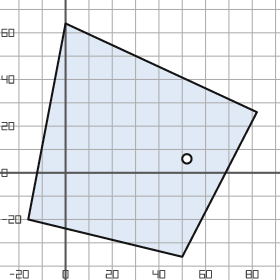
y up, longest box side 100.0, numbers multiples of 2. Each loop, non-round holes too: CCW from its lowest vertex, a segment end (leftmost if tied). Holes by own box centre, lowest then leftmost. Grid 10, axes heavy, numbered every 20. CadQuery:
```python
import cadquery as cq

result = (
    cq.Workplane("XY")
    .moveTo(50.0, -36.0)
    .lineTo(82.0, 26.0)
    .lineTo(0.0, 64.0)
    .lineTo(-16.0, -20.0)
    .close()
    .moveTo(52.0, 6.0)
    .circle(2.0)
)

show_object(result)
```